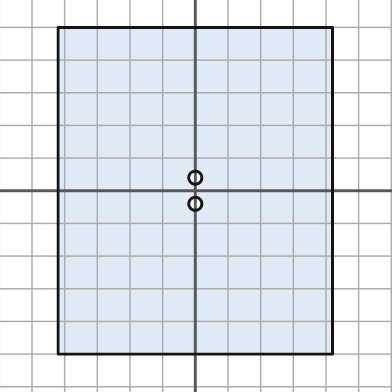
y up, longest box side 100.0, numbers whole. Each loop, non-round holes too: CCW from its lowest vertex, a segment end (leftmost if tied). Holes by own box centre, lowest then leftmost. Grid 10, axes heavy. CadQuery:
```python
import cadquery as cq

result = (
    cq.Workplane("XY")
    .moveTo(-42.0, -50.0)
    .lineTo(42.0, -50.0)
    .lineTo(42.0, 50.0)
    .lineTo(-42.0, 50.0)
    .close()
    .moveTo(0.0, -4.0)
    .circle(2.0)
    .moveTo(0.0, 4.0)
    .circle(2.0)
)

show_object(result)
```